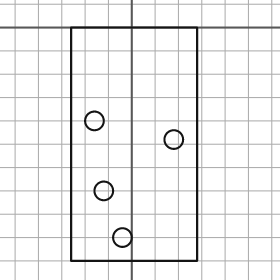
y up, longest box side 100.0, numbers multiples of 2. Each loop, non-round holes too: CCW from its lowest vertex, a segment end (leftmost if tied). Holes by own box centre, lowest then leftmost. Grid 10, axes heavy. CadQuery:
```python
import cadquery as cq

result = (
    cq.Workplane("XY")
    .moveTo(-26.0, -100.0)
    .lineTo(28.0, -100.0)
    .lineTo(28.0, 0.0)
    .lineTo(-26.0, 0.0)
    .close()
    .moveTo(-4.0, -90.0)
    .circle(4.0)
    .moveTo(-12.0, -70.0)
    .circle(4.0)
    .moveTo(18.0, -48.0)
    .circle(4.0)
    .moveTo(-16.0, -40.0)
    .circle(4.0)
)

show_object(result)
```